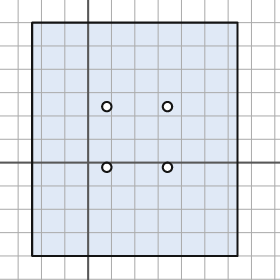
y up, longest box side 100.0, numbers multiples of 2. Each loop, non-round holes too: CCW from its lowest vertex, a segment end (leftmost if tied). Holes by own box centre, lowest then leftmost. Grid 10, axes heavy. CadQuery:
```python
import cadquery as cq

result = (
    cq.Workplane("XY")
    .moveTo(-24.0, -40.0)
    .lineTo(64.0, -40.0)
    .lineTo(64.0, 60.0)
    .lineTo(-24.0, 60.0)
    .close()
    .moveTo(8.0, -2.0)
    .circle(2.0)
    .moveTo(34.0, -2.0)
    .circle(2.0)
    .moveTo(8.0, 24.0)
    .circle(2.0)
    .moveTo(34.0, 24.0)
    .circle(2.0)
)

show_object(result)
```